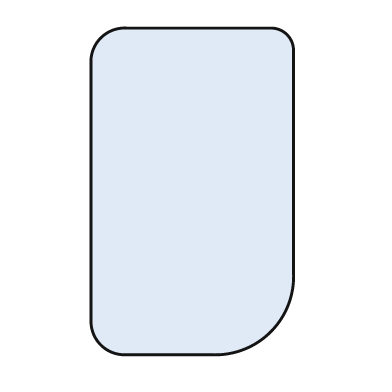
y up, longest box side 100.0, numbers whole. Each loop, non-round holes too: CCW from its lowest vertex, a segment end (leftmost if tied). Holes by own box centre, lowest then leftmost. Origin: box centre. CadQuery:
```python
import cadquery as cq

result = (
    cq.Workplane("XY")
    .moveTo(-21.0, -50.0)
    .lineTo(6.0, -50.0)
    .threePointArc((24.0, -43.0), (31.0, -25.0))
    .lineTo(31.0, 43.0)
    .threePointArc((29.0, 48.0), (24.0, 50.0))
    .lineTo(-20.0, 50.0)
    .threePointArc((-28.0, 47.0), (-31.0, 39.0))
    .lineTo(-31.0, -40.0)
    .threePointArc((-28.0, -47.0), (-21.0, -50.0))
    .close()
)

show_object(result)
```